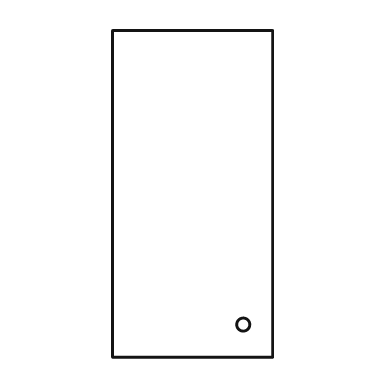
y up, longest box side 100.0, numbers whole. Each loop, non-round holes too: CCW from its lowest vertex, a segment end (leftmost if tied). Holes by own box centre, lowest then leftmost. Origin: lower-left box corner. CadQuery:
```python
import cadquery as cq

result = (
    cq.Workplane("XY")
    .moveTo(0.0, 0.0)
    .lineTo(49.0, 0.0)
    .lineTo(49.0, 100.0)
    .lineTo(0.0, 100.0)
    .close()
    .moveTo(40.0, 10.0)
    .circle(2.0)
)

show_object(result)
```